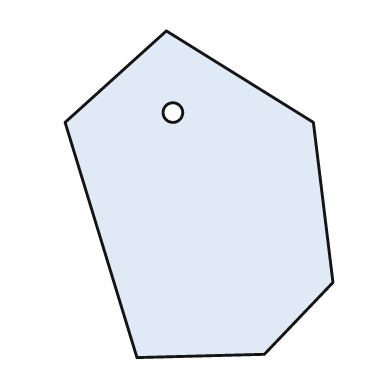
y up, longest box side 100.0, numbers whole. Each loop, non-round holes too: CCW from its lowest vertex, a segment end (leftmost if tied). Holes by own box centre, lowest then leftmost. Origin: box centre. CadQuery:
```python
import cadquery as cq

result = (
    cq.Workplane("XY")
    .moveTo(-19.0, -50.0)
    .lineTo(20.0, -49.0)
    .lineTo(41.0, -27.0)
    .lineTo(35.0, 22.0)
    .lineTo(-10.0, 50.0)
    .lineTo(-41.0, 22.0)
    .close()
    .moveTo(-8.0, 25.0)
    .circle(3.0)
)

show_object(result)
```